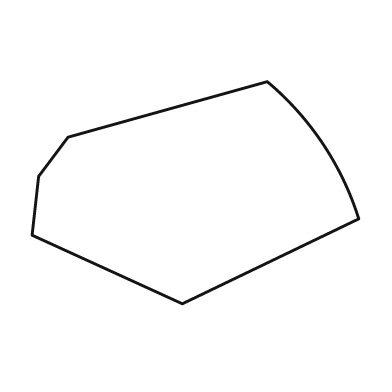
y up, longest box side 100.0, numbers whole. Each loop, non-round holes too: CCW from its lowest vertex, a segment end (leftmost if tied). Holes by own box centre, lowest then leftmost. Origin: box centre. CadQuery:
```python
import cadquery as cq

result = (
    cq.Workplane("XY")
    .moveTo(-4.0, -34.0)
    .lineTo(50.0, -8.0)
    .threePointArc((39.0, 15.0), (22.0, 34.0))
    .lineTo(-39.0, 17.0)
    .lineTo(-48.0, 5.0)
    .lineTo(-50.0, -13.0)
    .close()
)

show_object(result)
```